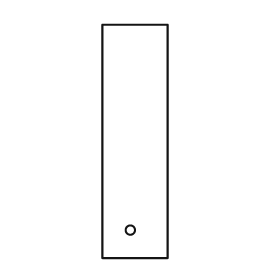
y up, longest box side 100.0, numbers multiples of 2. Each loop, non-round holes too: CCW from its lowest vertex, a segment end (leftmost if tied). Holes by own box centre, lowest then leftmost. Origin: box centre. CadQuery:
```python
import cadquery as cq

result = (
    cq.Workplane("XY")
    .moveTo(-14.0, -50.0)
    .lineTo(14.0, -50.0)
    .lineTo(14.0, 50.0)
    .lineTo(-14.0, 50.0)
    .close()
    .moveTo(-2.0, -38.0)
    .circle(2.0)
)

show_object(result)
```